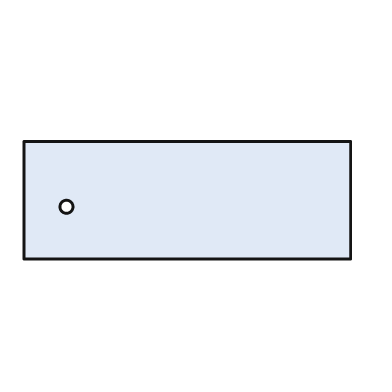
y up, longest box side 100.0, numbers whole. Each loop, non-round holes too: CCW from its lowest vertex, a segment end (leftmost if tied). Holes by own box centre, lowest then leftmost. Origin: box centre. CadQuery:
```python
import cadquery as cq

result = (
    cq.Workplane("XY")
    .moveTo(-50.0, -18.0)
    .lineTo(50.0, -18.0)
    .lineTo(50.0, 18.0)
    .lineTo(-50.0, 18.0)
    .close()
    .moveTo(-37.0, -2.0)
    .circle(2.0)
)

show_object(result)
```